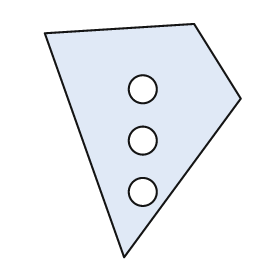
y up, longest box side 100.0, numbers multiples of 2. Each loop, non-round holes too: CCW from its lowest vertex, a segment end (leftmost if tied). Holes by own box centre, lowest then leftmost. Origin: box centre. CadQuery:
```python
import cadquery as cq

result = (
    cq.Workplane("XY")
    .moveTo(-8.0, -50.0)
    .lineTo(42.0, 18.0)
    .lineTo(22.0, 50.0)
    .lineTo(-42.0, 46.0)
    .close()
    .moveTo(0.0, -22.0)
    .circle(6.0)
    .moveTo(0.0, 0.0)
    .circle(6.0)
    .moveTo(0.0, 22.0)
    .circle(6.0)
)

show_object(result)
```